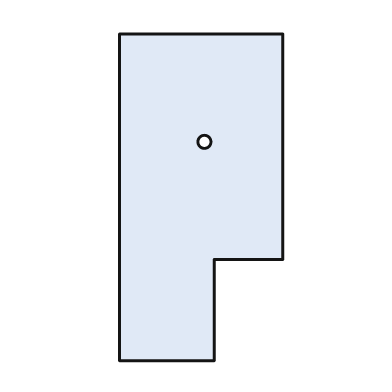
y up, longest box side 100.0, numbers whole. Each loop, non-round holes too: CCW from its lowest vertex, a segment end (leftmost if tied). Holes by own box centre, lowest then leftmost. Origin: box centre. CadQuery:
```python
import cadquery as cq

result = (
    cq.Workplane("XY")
    .moveTo(-25.0, -50.0)
    .lineTo(4.0, -50.0)
    .lineTo(4.0, -19.0)
    .lineTo(25.0, -19.0)
    .lineTo(25.0, 50.0)
    .lineTo(-25.0, 50.0)
    .close()
    .moveTo(1.0, 17.0)
    .circle(2.0)
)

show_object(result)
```